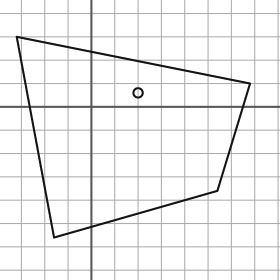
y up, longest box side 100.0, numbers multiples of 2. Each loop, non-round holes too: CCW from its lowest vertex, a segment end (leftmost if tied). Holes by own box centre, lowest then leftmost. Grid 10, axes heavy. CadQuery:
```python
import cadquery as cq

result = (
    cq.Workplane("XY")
    .moveTo(-16.0, -56.0)
    .lineTo(54.0, -36.0)
    .lineTo(68.0, 10.0)
    .lineTo(-32.0, 30.0)
    .close()
    .moveTo(20.0, 6.0)
    .circle(2.0)
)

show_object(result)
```